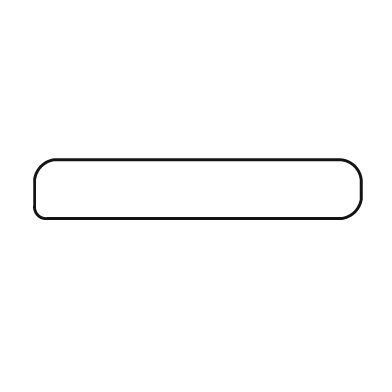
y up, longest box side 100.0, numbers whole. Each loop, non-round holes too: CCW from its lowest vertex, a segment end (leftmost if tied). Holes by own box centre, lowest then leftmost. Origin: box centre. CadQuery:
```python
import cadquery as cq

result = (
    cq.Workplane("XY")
    .moveTo(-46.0, -9.0)
    .lineTo(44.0, -9.0)
    .threePointArc((48.0, -7.0), (50.0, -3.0))
    .lineTo(50.0, 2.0)
    .threePointArc((48.0, 7.0), (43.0, 9.0))
    .lineTo(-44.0, 9.0)
    .threePointArc((-48.0, 7.0), (-50.0, 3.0))
    .lineTo(-50.0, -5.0)
    .threePointArc((-49.0, -8.0), (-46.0, -9.0))
    .close()
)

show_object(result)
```